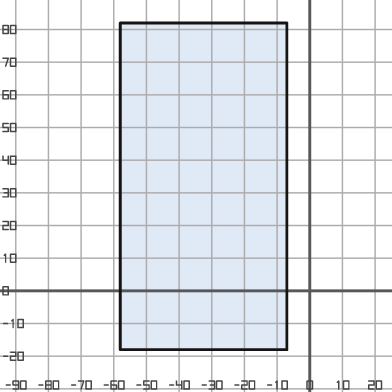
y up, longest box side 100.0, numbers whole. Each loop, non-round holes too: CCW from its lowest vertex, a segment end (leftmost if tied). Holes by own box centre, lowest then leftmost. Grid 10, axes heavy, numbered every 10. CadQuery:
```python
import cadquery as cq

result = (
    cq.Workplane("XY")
    .moveTo(-58.0, -18.0)
    .lineTo(-7.0, -18.0)
    .lineTo(-7.0, 82.0)
    .lineTo(-58.0, 82.0)
    .close()
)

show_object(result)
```